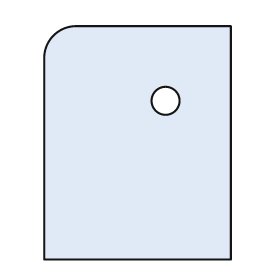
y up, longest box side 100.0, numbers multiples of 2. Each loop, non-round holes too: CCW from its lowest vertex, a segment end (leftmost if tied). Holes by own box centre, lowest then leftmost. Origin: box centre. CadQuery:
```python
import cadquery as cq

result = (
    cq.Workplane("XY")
    .moveTo(-40.0, -50.0)
    .lineTo(40.0, -50.0)
    .lineTo(40.0, 50.0)
    .lineTo(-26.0, 50.0)
    .threePointArc((-36.0, 46.0), (-40.0, 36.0))
    .close()
    .moveTo(12.0, 18.0)
    .circle(6.0)
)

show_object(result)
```